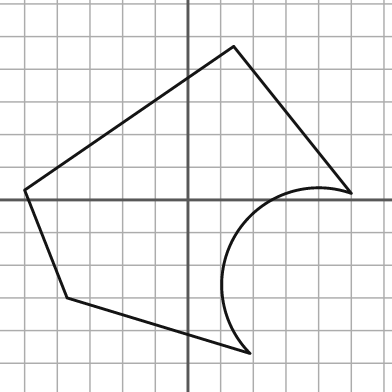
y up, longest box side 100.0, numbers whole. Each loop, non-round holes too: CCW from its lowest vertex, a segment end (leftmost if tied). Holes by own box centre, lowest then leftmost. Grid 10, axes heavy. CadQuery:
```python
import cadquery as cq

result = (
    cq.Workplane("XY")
    .moveTo(19.0, -47.0)
    .threePointArc((15.0, -10.0), (50.0, 2.0))
    .lineTo(14.0, 47.0)
    .lineTo(-50.0, 3.0)
    .lineTo(-37.0, -30.0)
    .close()
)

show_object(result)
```